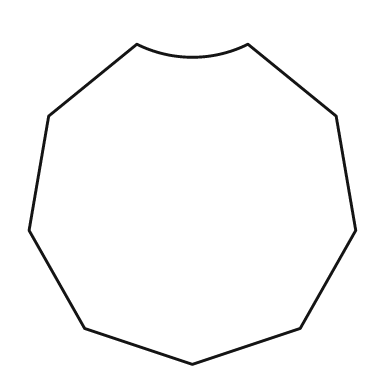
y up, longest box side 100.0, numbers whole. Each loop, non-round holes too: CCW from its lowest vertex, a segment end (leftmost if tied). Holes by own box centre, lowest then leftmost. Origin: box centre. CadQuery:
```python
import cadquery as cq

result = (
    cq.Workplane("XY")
    .moveTo(0.0, -49.0)
    .lineTo(33.0, -38.0)
    .lineTo(50.0, -8.0)
    .lineTo(44.0, 27.0)
    .lineTo(17.0, 49.0)
    .threePointArc((0.0, 45.0), (-17.0, 49.0))
    .lineTo(-44.0, 27.0)
    .lineTo(-50.0, -8.0)
    .lineTo(-33.0, -38.0)
    .close()
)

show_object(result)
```